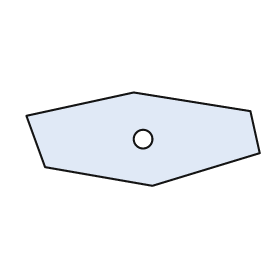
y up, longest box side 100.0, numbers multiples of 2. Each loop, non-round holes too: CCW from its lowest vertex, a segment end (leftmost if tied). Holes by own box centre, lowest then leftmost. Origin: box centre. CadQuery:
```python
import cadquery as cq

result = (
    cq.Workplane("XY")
    .moveTo(4.0, -20.0)
    .lineTo(50.0, -6.0)
    .lineTo(46.0, 12.0)
    .lineTo(-4.0, 20.0)
    .lineTo(-50.0, 10.0)
    .lineTo(-42.0, -12.0)
    .close()
    .moveTo(0.0, 0.0)
    .circle(4.0)
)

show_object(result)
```